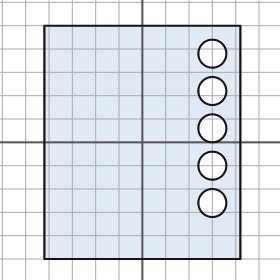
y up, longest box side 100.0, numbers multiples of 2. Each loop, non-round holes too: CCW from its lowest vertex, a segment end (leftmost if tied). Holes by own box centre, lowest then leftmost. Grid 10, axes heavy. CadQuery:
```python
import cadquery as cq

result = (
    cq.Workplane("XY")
    .moveTo(-42.0, -50.0)
    .lineTo(42.0, -50.0)
    .lineTo(42.0, 50.0)
    .lineTo(-42.0, 50.0)
    .close()
    .moveTo(30.0, -26.0)
    .circle(6.0)
    .moveTo(30.0, -10.0)
    .circle(6.0)
    .moveTo(30.0, 6.0)
    .circle(6.0)
    .moveTo(30.0, 22.0)
    .circle(6.0)
    .moveTo(30.0, 38.0)
    .circle(6.0)
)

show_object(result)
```